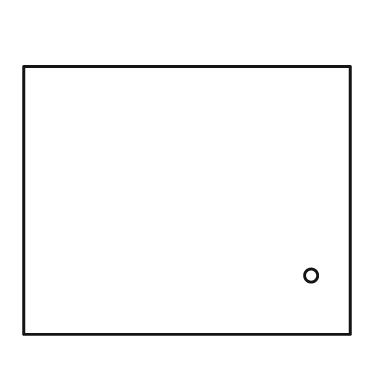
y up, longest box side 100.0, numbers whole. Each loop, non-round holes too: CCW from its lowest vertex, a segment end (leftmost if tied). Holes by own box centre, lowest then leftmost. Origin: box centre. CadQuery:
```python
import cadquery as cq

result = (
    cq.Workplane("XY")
    .moveTo(-50.0, -41.0)
    .lineTo(50.0, -41.0)
    .lineTo(50.0, 41.0)
    .lineTo(-50.0, 41.0)
    .close()
    .moveTo(38.0, -23.0)
    .circle(2.0)
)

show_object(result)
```